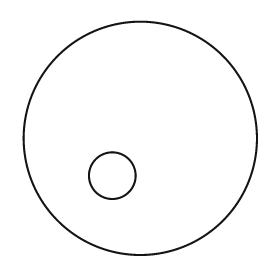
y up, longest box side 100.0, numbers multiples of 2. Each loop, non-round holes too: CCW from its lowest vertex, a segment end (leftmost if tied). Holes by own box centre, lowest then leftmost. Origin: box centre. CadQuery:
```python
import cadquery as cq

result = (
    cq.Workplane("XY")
    .moveTo(0.0, 0.0)
    .circle(50.0)
    .moveTo(-12.0, -16.0)
    .circle(10.0)
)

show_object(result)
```